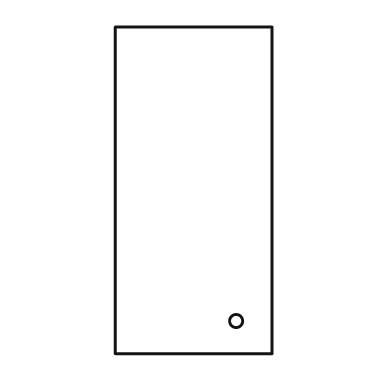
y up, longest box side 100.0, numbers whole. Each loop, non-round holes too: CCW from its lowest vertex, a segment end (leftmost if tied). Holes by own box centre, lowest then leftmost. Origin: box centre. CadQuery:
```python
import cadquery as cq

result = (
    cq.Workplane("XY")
    .moveTo(-24.0, -50.0)
    .lineTo(24.0, -50.0)
    .lineTo(24.0, 50.0)
    .lineTo(-24.0, 50.0)
    .close()
    .moveTo(13.0, -40.0)
    .circle(2.0)
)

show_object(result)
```